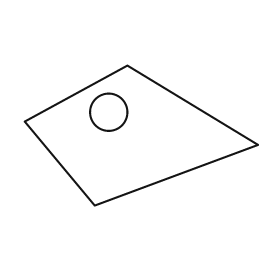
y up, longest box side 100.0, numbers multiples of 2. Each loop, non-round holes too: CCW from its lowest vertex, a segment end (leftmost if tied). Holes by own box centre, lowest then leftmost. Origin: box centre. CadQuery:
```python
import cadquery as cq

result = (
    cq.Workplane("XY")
    .moveTo(-20.0, -30.0)
    .lineTo(50.0, -4.0)
    .lineTo(-6.0, 30.0)
    .lineTo(-50.0, 6.0)
    .close()
    .moveTo(-14.0, 10.0)
    .circle(8.0)
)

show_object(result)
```